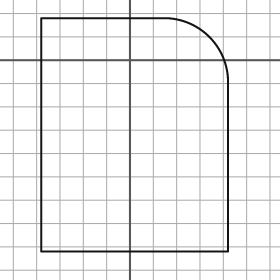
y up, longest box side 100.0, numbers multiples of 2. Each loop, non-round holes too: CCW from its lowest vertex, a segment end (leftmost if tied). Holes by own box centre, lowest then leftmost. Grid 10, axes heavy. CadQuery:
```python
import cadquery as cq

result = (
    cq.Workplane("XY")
    .moveTo(-38.0, -82.0)
    .lineTo(42.0, -82.0)
    .lineTo(42.0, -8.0)
    .threePointArc((34.0, 10.0), (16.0, 18.0))
    .lineTo(-38.0, 18.0)
    .close()
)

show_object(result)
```